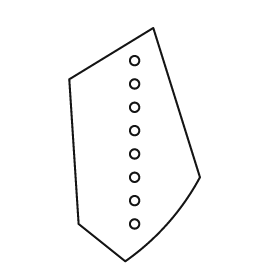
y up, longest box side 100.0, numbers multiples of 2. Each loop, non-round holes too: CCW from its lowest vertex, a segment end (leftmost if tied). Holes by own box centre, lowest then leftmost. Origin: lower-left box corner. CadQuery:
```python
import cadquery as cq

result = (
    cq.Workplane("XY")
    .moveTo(24.0, 0.0)
    .threePointArc((42.0, 16.0), (56.0, 36.0))
    .lineTo(36.0, 100.0)
    .lineTo(0.0, 78.0)
    .lineTo(4.0, 16.0)
    .close()
    .moveTo(28.0, 16.0)
    .circle(2.0)
    .moveTo(28.0, 26.0)
    .circle(2.0)
    .moveTo(28.0, 36.0)
    .circle(2.0)
    .moveTo(28.0, 46.0)
    .circle(2.0)
    .moveTo(28.0, 56.0)
    .circle(2.0)
    .moveTo(28.0, 66.0)
    .circle(2.0)
    .moveTo(28.0, 76.0)
    .circle(2.0)
    .moveTo(28.0, 86.0)
    .circle(2.0)
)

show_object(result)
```